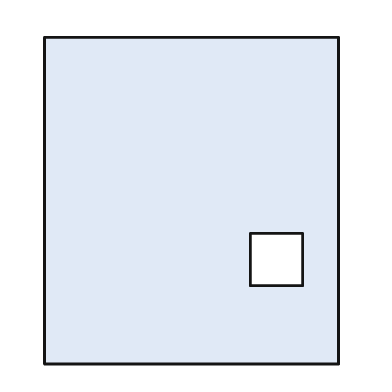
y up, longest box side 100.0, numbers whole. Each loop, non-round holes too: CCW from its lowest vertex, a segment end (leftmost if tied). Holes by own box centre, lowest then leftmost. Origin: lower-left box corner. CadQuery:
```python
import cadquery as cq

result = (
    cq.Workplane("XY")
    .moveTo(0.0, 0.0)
    .lineTo(90.0, 0.0)
    .lineTo(90.0, 100.0)
    .lineTo(0.0, 100.0)
    .close()
    .moveTo(63.0, 24.0)
    .lineTo(79.0, 24.0)
    .lineTo(79.0, 40.0)
    .lineTo(63.0, 40.0)
    .close()
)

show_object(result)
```